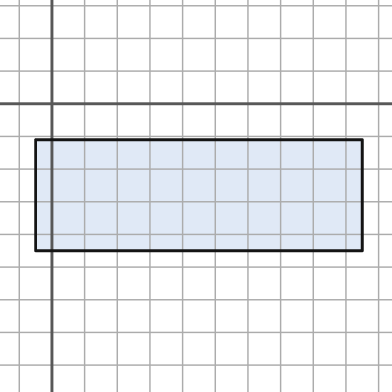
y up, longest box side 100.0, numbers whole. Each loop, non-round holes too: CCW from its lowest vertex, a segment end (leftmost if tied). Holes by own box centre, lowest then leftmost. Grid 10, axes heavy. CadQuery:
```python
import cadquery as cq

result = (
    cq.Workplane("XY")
    .moveTo(-5.0, -45.0)
    .lineTo(95.0, -45.0)
    .lineTo(95.0, -11.0)
    .lineTo(-5.0, -11.0)
    .close()
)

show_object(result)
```